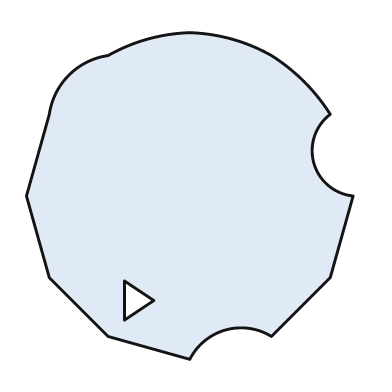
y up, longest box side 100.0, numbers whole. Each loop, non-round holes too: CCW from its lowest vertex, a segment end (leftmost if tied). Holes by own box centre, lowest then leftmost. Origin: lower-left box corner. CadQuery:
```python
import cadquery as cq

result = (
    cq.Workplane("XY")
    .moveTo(50.0, 0.0)
    .threePointArc((61.0, 9.0), (75.0, 7.0))
    .lineTo(93.0, 25.0)
    .lineTo(100.0, 50.0)
    .threePointArc((88.0, 60.0), (93.0, 75.0))
    .threePointArc((85.0, 85.0), (75.0, 93.0))
    .threePointArc((63.0, 98.0), (50.0, 100.0))
    .threePointArc((37.0, 98.0), (25.0, 93.0))
    .threePointArc((13.0, 87.0), (7.0, 75.0))
    .lineTo(0.0, 50.0)
    .lineTo(7.0, 25.0)
    .lineTo(25.0, 7.0)
    .close()
    .moveTo(30.0, 12.0)
    .lineTo(39.0, 18.0)
    .lineTo(30.0, 24.0)
    .close()
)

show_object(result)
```